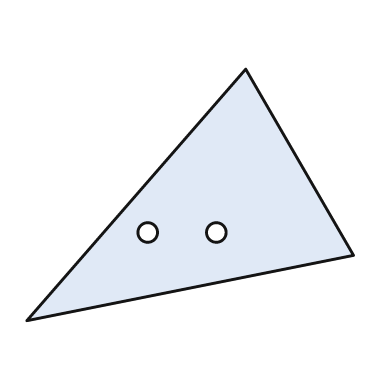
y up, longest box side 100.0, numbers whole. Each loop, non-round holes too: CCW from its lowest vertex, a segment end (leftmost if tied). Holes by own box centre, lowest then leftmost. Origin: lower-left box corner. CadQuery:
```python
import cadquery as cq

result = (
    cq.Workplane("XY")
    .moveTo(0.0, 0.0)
    .lineTo(100.0, 20.0)
    .lineTo(67.0, 77.0)
    .close()
    .moveTo(37.0, 27.0)
    .circle(3.0)
    .moveTo(58.0, 27.0)
    .circle(3.0)
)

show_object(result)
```